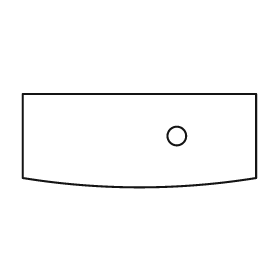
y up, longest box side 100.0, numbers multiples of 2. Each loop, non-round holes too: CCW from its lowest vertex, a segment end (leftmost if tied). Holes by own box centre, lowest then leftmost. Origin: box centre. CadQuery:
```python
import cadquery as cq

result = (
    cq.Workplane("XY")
    .moveTo(-50.0, -16.0)
    .threePointArc((0.0, -20.0), (50.0, -16.0))
    .lineTo(50.0, 20.0)
    .lineTo(-50.0, 20.0)
    .close()
    .moveTo(16.0, 2.0)
    .circle(4.0)
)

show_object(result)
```